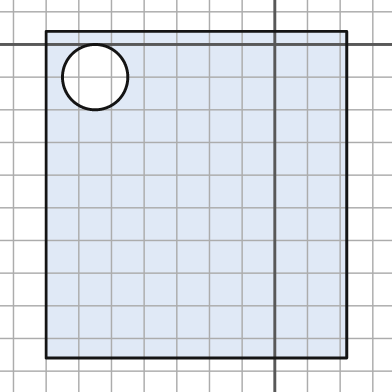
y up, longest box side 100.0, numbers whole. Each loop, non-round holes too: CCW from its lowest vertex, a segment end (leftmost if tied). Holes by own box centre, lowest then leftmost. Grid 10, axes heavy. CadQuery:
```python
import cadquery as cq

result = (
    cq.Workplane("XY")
    .moveTo(-70.0, -96.0)
    .lineTo(22.0, -96.0)
    .lineTo(22.0, 4.0)
    .lineTo(-70.0, 4.0)
    .close()
    .moveTo(-55.0, -10.0)
    .circle(10.0)
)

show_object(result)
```